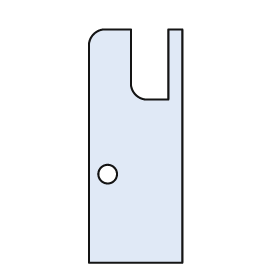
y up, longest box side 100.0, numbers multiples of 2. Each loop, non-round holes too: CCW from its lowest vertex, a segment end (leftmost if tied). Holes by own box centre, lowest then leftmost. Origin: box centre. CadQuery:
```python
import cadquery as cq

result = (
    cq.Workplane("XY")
    .moveTo(-20.0, -50.0)
    .lineTo(20.0, -50.0)
    .lineTo(20.0, 50.0)
    .lineTo(14.0, 50.0)
    .lineTo(14.0, 20.0)
    .lineTo(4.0, 20.0)
    .threePointArc((0.0, 22.0), (-2.0, 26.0))
    .lineTo(-2.0, 50.0)
    .lineTo(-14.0, 50.0)
    .threePointArc((-18.0, 48.0), (-20.0, 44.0))
    .close()
    .moveTo(-12.0, -12.0)
    .circle(4.0)
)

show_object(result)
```